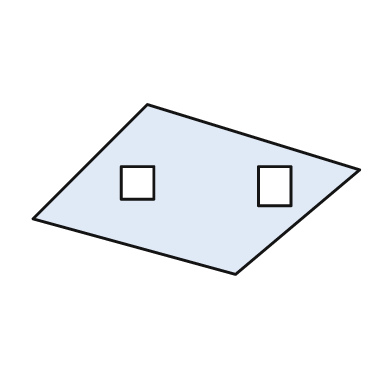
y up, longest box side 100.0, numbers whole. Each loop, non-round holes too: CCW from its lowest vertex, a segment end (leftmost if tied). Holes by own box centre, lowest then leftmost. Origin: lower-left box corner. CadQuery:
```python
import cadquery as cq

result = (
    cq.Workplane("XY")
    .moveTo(62.0, 0.0)
    .lineTo(100.0, 32.0)
    .lineTo(35.0, 52.0)
    .lineTo(0.0, 17.0)
    .close()
    .moveTo(69.0, 21.0)
    .lineTo(79.0, 21.0)
    .lineTo(79.0, 33.0)
    .lineTo(69.0, 33.0)
    .close()
    .moveTo(27.0, 23.0)
    .lineTo(37.0, 23.0)
    .lineTo(37.0, 33.0)
    .lineTo(27.0, 33.0)
    .close()
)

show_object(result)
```